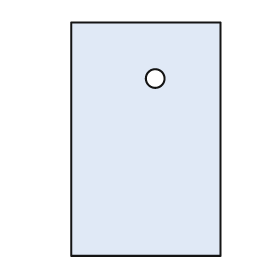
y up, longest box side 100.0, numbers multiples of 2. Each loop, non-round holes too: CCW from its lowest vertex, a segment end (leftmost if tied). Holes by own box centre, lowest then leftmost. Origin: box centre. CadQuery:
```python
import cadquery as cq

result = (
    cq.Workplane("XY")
    .moveTo(-32.0, -50.0)
    .lineTo(32.0, -50.0)
    .lineTo(32.0, 50.0)
    .lineTo(-32.0, 50.0)
    .close()
    .moveTo(4.0, 26.0)
    .circle(4.0)
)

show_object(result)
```